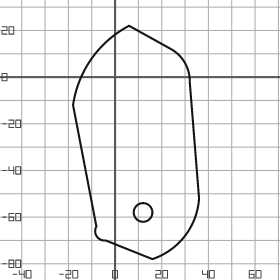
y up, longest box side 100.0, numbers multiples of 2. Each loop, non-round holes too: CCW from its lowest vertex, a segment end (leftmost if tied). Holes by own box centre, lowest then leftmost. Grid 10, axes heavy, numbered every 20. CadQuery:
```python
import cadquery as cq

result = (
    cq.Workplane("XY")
    .moveTo(16.0, -78.0)
    .threePointArc((30.0, -68.0), (36.0, -52.0))
    .lineTo(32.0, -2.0)
    .threePointArc((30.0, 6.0), (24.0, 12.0))
    .lineTo(6.0, 22.0)
    .threePointArc((-10.0, 8.0), (-18.0, -12.0))
    .lineTo(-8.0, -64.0)
    .threePointArc((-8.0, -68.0), (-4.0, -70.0))
    .close()
    .moveTo(12.0, -58.0)
    .circle(4.0)
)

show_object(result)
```